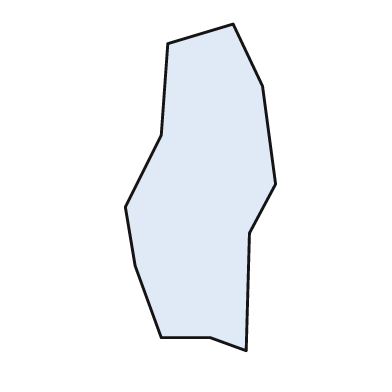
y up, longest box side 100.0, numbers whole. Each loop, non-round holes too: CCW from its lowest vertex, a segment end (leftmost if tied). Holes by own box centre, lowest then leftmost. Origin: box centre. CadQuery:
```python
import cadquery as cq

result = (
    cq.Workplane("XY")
    .moveTo(14.0, -50.0)
    .lineTo(15.0, -14.0)
    .lineTo(23.0, 1.0)
    .lineTo(19.0, 31.0)
    .lineTo(10.0, 50.0)
    .lineTo(-10.0, 44.0)
    .lineTo(-12.0, 16.0)
    .lineTo(-23.0, -6.0)
    .lineTo(-20.0, -24.0)
    .lineTo(-12.0, -46.0)
    .lineTo(3.0, -46.0)
    .close()
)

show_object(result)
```